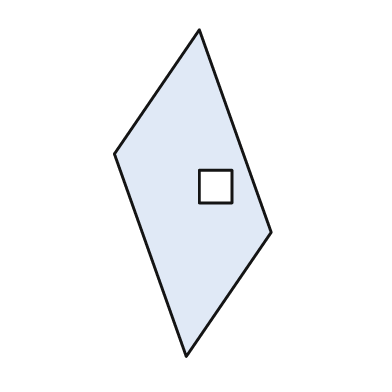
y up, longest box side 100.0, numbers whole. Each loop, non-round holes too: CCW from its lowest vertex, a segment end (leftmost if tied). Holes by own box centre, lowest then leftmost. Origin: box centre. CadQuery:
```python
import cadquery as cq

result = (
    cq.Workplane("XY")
    .moveTo(-2.0, -50.0)
    .lineTo(24.0, -12.0)
    .lineTo(2.0, 50.0)
    .lineTo(-24.0, 12.0)
    .close()
    .moveTo(2.0, -3.0)
    .lineTo(12.0, -3.0)
    .lineTo(12.0, 7.0)
    .lineTo(2.0, 7.0)
    .close()
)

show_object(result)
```